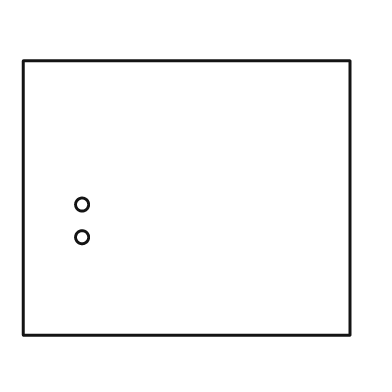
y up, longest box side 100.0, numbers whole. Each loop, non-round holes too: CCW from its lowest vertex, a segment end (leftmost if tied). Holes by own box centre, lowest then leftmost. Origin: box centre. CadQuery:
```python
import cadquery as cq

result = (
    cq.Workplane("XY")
    .moveTo(-50.0, -42.0)
    .lineTo(50.0, -42.0)
    .lineTo(50.0, 42.0)
    .lineTo(-50.0, 42.0)
    .close()
    .moveTo(-32.0, -12.0)
    .circle(2.0)
    .moveTo(-32.0, -2.0)
    .circle(2.0)
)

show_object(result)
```